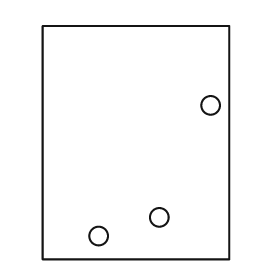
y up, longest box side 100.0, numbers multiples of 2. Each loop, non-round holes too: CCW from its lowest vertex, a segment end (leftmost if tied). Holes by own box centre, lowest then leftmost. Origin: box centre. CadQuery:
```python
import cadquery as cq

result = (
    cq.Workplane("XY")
    .moveTo(-40.0, -50.0)
    .lineTo(40.0, -50.0)
    .lineTo(40.0, 50.0)
    .lineTo(-40.0, 50.0)
    .close()
    .moveTo(-16.0, -40.0)
    .circle(4.0)
    .moveTo(10.0, -32.0)
    .circle(4.0)
    .moveTo(32.0, 16.0)
    .circle(4.0)
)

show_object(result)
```